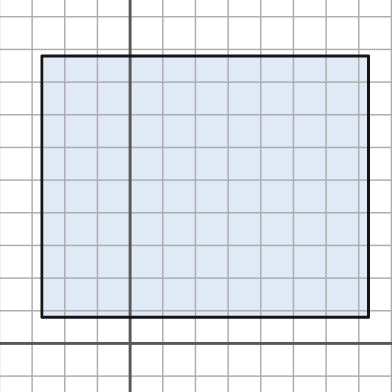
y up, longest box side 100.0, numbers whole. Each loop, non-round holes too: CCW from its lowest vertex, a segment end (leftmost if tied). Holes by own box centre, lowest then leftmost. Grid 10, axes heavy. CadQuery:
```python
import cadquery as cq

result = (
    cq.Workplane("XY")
    .moveTo(-27.0, 8.0)
    .lineTo(73.0, 8.0)
    .lineTo(73.0, 88.0)
    .lineTo(-27.0, 88.0)
    .close()
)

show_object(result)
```